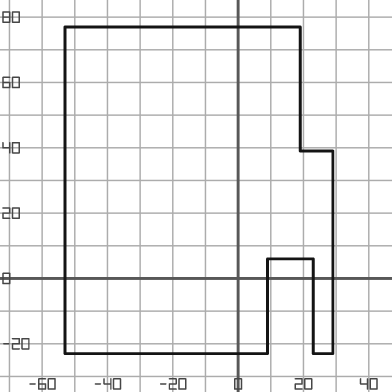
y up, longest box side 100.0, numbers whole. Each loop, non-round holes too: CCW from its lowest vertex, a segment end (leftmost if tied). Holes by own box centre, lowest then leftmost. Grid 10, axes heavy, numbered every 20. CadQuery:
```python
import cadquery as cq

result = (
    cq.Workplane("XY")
    .moveTo(-53.0, -23.0)
    .lineTo(9.0, -23.0)
    .lineTo(9.0, 6.0)
    .lineTo(23.0, 6.0)
    .lineTo(23.0, -23.0)
    .lineTo(29.0, -23.0)
    .lineTo(29.0, 39.0)
    .lineTo(19.0, 39.0)
    .lineTo(19.0, 77.0)
    .lineTo(-53.0, 77.0)
    .close()
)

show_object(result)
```